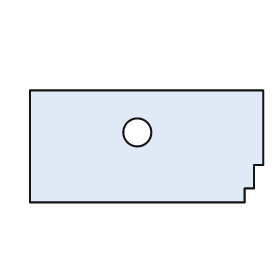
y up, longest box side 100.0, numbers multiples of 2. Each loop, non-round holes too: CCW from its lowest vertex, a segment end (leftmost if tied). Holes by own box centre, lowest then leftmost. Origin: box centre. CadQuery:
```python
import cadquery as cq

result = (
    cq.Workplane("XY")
    .moveTo(-50.0, -24.0)
    .lineTo(42.0, -24.0)
    .lineTo(42.0, -18.0)
    .lineTo(46.0, -18.0)
    .lineTo(46.0, -8.0)
    .lineTo(50.0, -8.0)
    .lineTo(50.0, 24.0)
    .lineTo(-50.0, 24.0)
    .close()
    .moveTo(-4.0, 6.0)
    .circle(6.0)
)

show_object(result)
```